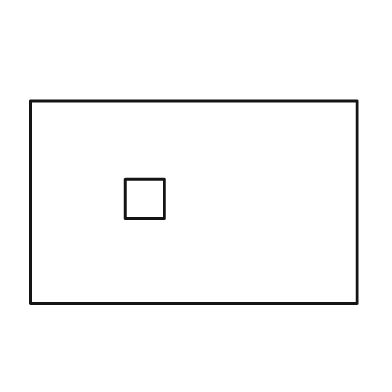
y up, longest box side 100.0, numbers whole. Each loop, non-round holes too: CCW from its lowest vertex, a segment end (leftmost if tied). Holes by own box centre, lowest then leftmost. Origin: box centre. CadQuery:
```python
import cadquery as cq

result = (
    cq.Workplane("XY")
    .moveTo(-50.0, -31.0)
    .lineTo(50.0, -31.0)
    .lineTo(50.0, 31.0)
    .lineTo(-50.0, 31.0)
    .close()
    .moveTo(-21.0, -5.0)
    .lineTo(-9.0, -5.0)
    .lineTo(-9.0, 7.0)
    .lineTo(-21.0, 7.0)
    .close()
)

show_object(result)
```